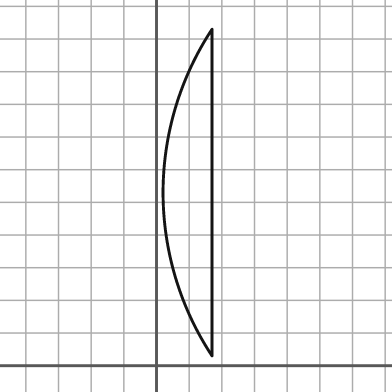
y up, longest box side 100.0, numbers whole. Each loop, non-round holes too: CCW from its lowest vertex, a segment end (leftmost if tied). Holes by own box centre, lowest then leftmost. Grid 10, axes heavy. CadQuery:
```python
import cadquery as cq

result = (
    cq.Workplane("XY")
    .moveTo(17.0, 3.0)
    .lineTo(17.0, 103.0)
    .threePointArc((2.0, 53.0), (17.0, 3.0))
    .close()
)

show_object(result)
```